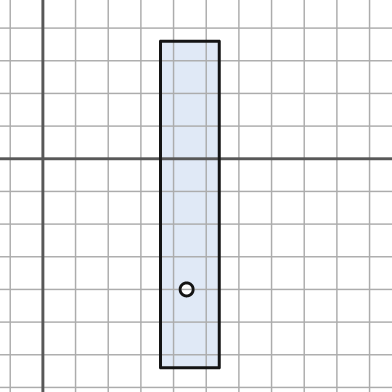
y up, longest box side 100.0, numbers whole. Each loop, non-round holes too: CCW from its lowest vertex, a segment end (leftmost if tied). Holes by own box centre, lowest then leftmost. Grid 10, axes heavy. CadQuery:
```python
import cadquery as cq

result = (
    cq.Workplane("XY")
    .moveTo(36.0, -64.0)
    .lineTo(54.0, -64.0)
    .lineTo(54.0, 36.0)
    .lineTo(36.0, 36.0)
    .close()
    .moveTo(44.0, -40.0)
    .circle(2.0)
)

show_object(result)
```